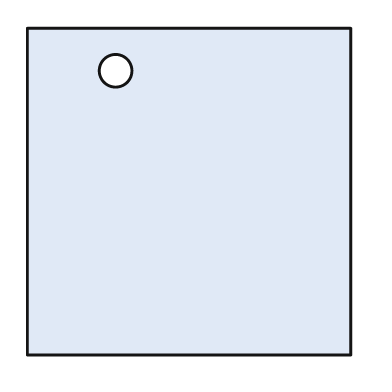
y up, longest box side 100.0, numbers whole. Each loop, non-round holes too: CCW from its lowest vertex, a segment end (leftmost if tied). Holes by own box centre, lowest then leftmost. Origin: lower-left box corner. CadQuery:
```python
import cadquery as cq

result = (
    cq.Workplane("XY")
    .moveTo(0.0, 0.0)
    .lineTo(99.0, 0.0)
    .lineTo(99.0, 100.0)
    .lineTo(0.0, 100.0)
    .close()
    .moveTo(27.0, 87.0)
    .circle(5.0)
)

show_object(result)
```